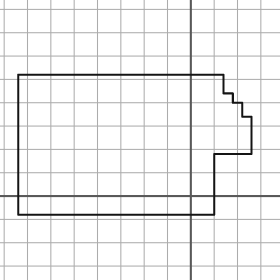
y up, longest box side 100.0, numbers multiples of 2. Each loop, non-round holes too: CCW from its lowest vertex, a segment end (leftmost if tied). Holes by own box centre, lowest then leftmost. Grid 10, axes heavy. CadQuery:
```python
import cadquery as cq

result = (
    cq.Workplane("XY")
    .moveTo(-74.0, -8.0)
    .lineTo(10.0, -8.0)
    .lineTo(10.0, 18.0)
    .lineTo(26.0, 18.0)
    .lineTo(26.0, 34.0)
    .lineTo(22.0, 34.0)
    .lineTo(22.0, 40.0)
    .lineTo(18.0, 40.0)
    .lineTo(18.0, 44.0)
    .lineTo(14.0, 44.0)
    .lineTo(14.0, 52.0)
    .lineTo(-74.0, 52.0)
    .close()
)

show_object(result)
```